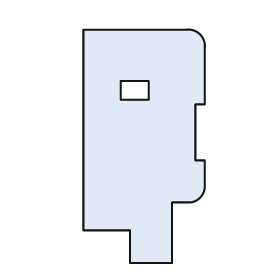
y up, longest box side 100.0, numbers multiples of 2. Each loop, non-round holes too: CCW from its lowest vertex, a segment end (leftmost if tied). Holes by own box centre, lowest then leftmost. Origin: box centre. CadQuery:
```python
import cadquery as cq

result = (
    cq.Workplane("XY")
    .moveTo(-6.0, -50.0)
    .lineTo(12.0, -50.0)
    .lineTo(12.0, -24.0)
    .lineTo(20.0, -24.0)
    .threePointArc((24.0, -22.0), (26.0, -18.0))
    .lineTo(26.0, -6.0)
    .lineTo(22.0, -6.0)
    .lineTo(22.0, 18.0)
    .lineTo(26.0, 18.0)
    .lineTo(26.0, 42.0)
    .threePointArc((24.0, 48.0), (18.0, 50.0))
    .lineTo(-26.0, 50.0)
    .lineTo(-26.0, -36.0)
    .lineTo(-6.0, -36.0)
    .close()
    .moveTo(-10.0, 20.0)
    .lineTo(2.0, 20.0)
    .lineTo(2.0, 28.0)
    .lineTo(-10.0, 28.0)
    .close()
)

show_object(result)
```